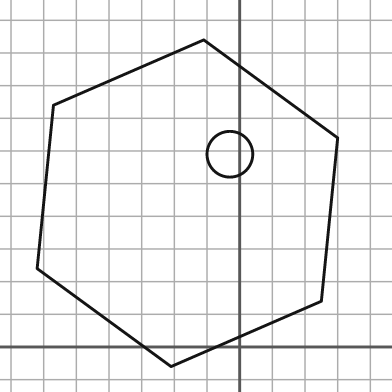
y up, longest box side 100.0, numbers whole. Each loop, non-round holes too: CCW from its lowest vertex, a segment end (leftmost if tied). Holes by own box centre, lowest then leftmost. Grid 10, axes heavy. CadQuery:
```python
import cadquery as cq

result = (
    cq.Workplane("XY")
    .moveTo(-21.0, -6.0)
    .lineTo(25.0, 14.0)
    .lineTo(30.0, 64.0)
    .lineTo(-11.0, 94.0)
    .lineTo(-57.0, 74.0)
    .lineTo(-62.0, 24.0)
    .close()
    .moveTo(-3.0, 59.0)
    .circle(7.0)
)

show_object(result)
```